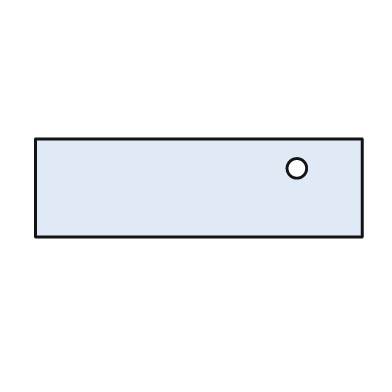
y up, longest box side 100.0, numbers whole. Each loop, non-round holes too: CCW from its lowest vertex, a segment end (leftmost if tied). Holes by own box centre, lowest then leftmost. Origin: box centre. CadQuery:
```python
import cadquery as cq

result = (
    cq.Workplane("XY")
    .moveTo(-50.0, -15.0)
    .lineTo(50.0, -15.0)
    .lineTo(50.0, 15.0)
    .lineTo(-50.0, 15.0)
    .close()
    .moveTo(30.0, 6.0)
    .circle(3.0)
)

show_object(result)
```